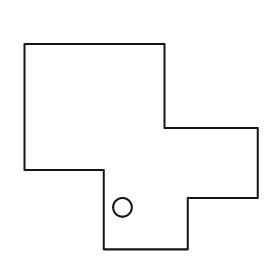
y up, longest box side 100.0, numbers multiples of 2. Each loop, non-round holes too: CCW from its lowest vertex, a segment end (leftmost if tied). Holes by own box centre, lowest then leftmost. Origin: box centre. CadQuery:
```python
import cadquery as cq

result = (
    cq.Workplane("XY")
    .moveTo(-16.0, -44.0)
    .lineTo(20.0, -44.0)
    .lineTo(20.0, -22.0)
    .lineTo(50.0, -22.0)
    .lineTo(50.0, 8.0)
    .lineTo(10.0, 8.0)
    .lineTo(10.0, 44.0)
    .lineTo(-50.0, 44.0)
    .lineTo(-50.0, -10.0)
    .lineTo(-16.0, -10.0)
    .close()
    .moveTo(-8.0, -26.0)
    .circle(4.0)
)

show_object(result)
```